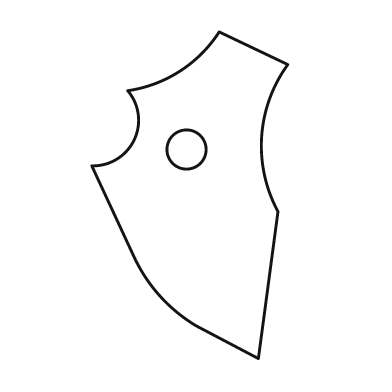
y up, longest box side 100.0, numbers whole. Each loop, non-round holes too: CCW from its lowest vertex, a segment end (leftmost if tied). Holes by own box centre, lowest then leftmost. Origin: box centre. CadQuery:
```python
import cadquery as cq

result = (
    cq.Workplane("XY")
    .moveTo(21.0, -50.0)
    .lineTo(27.0, -5.0)
    .threePointArc((22.0, 18.0), (30.0, 40.0))
    .lineTo(9.0, 50.0)
    .threePointArc((-3.0, 38.0), (-19.0, 32.0))
    .threePointArc((-17.0, 17.0), (-30.0, 9.0))
    .lineTo(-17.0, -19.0)
    .threePointArc((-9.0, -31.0), (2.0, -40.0))
    .close()
    .moveTo(-1.0, 14.0)
    .circle(6.0)
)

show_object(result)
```